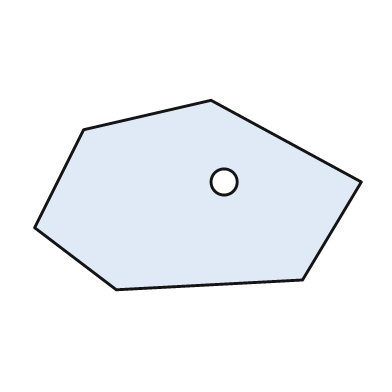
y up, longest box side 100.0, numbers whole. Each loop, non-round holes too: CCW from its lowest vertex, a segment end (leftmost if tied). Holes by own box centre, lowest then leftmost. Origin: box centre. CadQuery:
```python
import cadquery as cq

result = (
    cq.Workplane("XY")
    .moveTo(-25.0, -29.0)
    .lineTo(32.0, -26.0)
    .lineTo(50.0, 4.0)
    .lineTo(4.0, 29.0)
    .lineTo(-35.0, 20.0)
    .lineTo(-50.0, -10.0)
    .close()
    .moveTo(8.0, 4.0)
    .circle(4.0)
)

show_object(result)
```